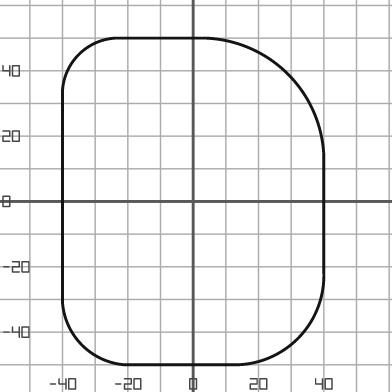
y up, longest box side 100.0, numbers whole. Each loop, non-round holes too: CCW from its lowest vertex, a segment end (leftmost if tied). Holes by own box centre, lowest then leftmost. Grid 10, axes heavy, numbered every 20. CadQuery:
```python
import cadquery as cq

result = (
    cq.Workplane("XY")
    .moveTo(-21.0, -50.0)
    .lineTo(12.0, -50.0)
    .threePointArc((32.0, -42.0), (40.0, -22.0))
    .lineTo(40.0, 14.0)
    .threePointArc((29.0, 39.0), (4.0, 50.0))
    .lineTo(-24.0, 50.0)
    .threePointArc((-35.0, 45.0), (-40.0, 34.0))
    .lineTo(-40.0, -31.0)
    .threePointArc((-34.0, -44.0), (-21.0, -50.0))
    .close()
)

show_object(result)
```